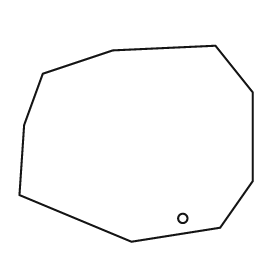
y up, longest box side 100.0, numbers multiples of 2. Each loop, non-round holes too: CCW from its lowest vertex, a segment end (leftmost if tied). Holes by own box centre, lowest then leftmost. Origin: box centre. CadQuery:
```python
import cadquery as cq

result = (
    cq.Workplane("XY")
    .moveTo(-2.0, -42.0)
    .lineTo(36.0, -36.0)
    .lineTo(50.0, -16.0)
    .lineTo(50.0, 22.0)
    .lineTo(34.0, 42.0)
    .lineTo(-10.0, 40.0)
    .lineTo(-40.0, 30.0)
    .lineTo(-48.0, 8.0)
    .lineTo(-50.0, -22.0)
    .close()
    .moveTo(20.0, -32.0)
    .circle(2.0)
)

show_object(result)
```